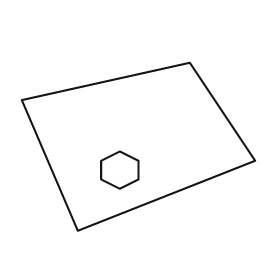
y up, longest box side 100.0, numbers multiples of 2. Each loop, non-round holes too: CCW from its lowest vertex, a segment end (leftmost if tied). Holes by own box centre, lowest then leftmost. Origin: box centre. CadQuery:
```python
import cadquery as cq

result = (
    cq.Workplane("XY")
    .moveTo(-26.0, -36.0)
    .lineTo(50.0, -6.0)
    .lineTo(22.0, 36.0)
    .lineTo(-50.0, 20.0)
    .close()
    .moveTo(-8.0, -18.0)
    .lineTo(0.0, -14.0)
    .lineTo(0.0, -6.0)
    .lineTo(-8.0, -2.0)
    .lineTo(-16.0, -6.0)
    .lineTo(-16.0, -14.0)
    .close()
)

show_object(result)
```